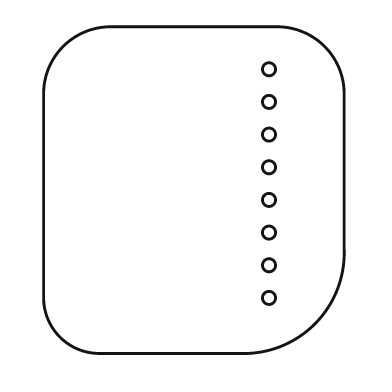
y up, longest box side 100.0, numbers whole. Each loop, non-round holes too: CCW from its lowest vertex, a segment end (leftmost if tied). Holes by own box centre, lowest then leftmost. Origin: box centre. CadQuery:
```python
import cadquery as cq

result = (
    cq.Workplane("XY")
    .moveTo(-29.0, -50.0)
    .lineTo(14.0, -50.0)
    .threePointArc((37.0, -41.0), (46.0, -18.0))
    .lineTo(46.0, 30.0)
    .threePointArc((40.0, 44.0), (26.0, 50.0))
    .lineTo(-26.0, 50.0)
    .threePointArc((-40.0, 44.0), (-46.0, 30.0))
    .lineTo(-46.0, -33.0)
    .threePointArc((-41.0, -45.0), (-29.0, -50.0))
    .close()
    .moveTo(23.0, -33.0)
    .circle(2.0)
    .moveTo(23.0, -23.0)
    .circle(2.0)
    .moveTo(23.0, -13.0)
    .circle(2.0)
    .moveTo(23.0, -3.0)
    .circle(2.0)
    .moveTo(23.0, 7.0)
    .circle(2.0)
    .moveTo(23.0, 17.0)
    .circle(2.0)
    .moveTo(23.0, 27.0)
    .circle(2.0)
    .moveTo(23.0, 37.0)
    .circle(2.0)
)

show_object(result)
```